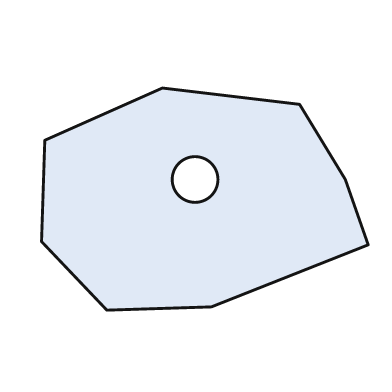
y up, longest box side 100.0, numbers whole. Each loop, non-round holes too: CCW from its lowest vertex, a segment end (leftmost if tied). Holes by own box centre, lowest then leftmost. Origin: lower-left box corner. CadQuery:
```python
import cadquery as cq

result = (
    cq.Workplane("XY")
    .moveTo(20.0, 0.0)
    .lineTo(52.0, 1.0)
    .lineTo(100.0, 20.0)
    .lineTo(93.0, 40.0)
    .lineTo(79.0, 63.0)
    .lineTo(37.0, 68.0)
    .lineTo(1.0, 52.0)
    .lineTo(0.0, 21.0)
    .close()
    .moveTo(47.0, 40.0)
    .circle(7.0)
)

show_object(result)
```